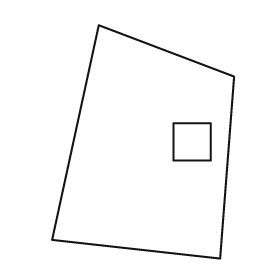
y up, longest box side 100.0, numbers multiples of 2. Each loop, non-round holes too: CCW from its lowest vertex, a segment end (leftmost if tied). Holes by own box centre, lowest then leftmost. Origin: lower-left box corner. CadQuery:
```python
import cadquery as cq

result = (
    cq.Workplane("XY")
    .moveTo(72.0, 0.0)
    .lineTo(78.0, 78.0)
    .lineTo(20.0, 100.0)
    .lineTo(0.0, 8.0)
    .close()
    .moveTo(52.0, 42.0)
    .lineTo(68.0, 42.0)
    .lineTo(68.0, 58.0)
    .lineTo(52.0, 58.0)
    .close()
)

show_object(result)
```